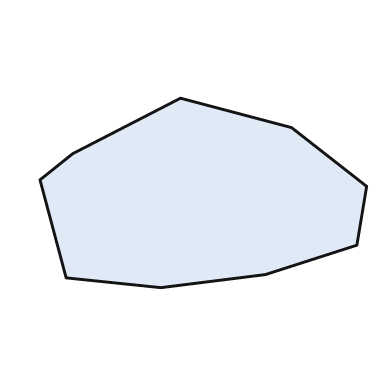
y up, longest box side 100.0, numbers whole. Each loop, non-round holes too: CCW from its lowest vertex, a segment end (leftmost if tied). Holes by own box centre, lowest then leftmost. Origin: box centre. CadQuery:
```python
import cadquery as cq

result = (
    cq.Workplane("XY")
    .moveTo(-13.0, -29.0)
    .lineTo(19.0, -25.0)
    .lineTo(47.0, -16.0)
    .lineTo(50.0, 2.0)
    .lineTo(27.0, 20.0)
    .lineTo(-7.0, 29.0)
    .lineTo(-40.0, 12.0)
    .lineTo(-50.0, 4.0)
    .lineTo(-42.0, -26.0)
    .close()
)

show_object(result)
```